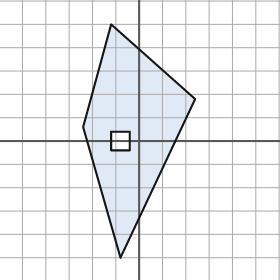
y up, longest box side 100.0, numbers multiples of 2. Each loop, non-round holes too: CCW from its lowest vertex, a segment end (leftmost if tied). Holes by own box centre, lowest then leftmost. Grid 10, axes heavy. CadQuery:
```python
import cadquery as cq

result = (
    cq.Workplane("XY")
    .moveTo(-8.0, -50.0)
    .lineTo(24.0, 18.0)
    .lineTo(-12.0, 50.0)
    .lineTo(-24.0, 6.0)
    .close()
    .moveTo(-12.0, -4.0)
    .lineTo(-4.0, -4.0)
    .lineTo(-4.0, 4.0)
    .lineTo(-12.0, 4.0)
    .close()
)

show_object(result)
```